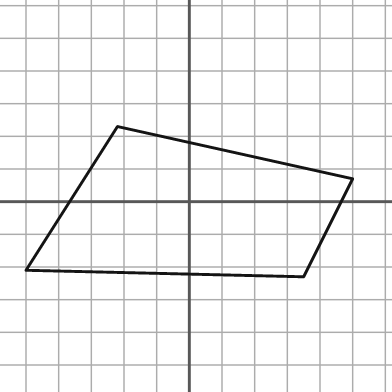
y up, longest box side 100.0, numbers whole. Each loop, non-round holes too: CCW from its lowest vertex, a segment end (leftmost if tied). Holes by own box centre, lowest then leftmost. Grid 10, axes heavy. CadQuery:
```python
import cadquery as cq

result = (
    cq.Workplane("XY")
    .moveTo(35.0, -23.0)
    .lineTo(50.0, 7.0)
    .lineTo(-22.0, 23.0)
    .lineTo(-50.0, -21.0)
    .close()
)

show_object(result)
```